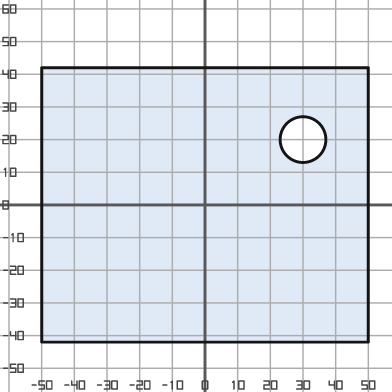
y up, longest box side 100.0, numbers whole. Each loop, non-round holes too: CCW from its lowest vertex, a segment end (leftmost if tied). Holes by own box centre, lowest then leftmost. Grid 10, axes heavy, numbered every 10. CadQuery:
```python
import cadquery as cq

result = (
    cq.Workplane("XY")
    .moveTo(-50.0, -42.0)
    .lineTo(50.0, -42.0)
    .lineTo(50.0, 42.0)
    .lineTo(-50.0, 42.0)
    .close()
    .moveTo(30.0, 20.0)
    .circle(7.0)
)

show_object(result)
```